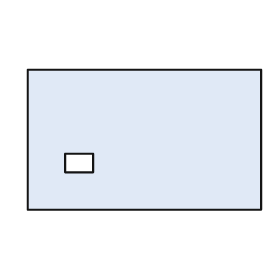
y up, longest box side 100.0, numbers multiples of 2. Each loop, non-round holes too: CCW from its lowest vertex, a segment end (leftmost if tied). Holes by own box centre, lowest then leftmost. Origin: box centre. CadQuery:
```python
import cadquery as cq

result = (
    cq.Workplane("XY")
    .moveTo(-50.0, -30.0)
    .lineTo(50.0, -30.0)
    .lineTo(50.0, 30.0)
    .lineTo(-50.0, 30.0)
    .close()
    .moveTo(-34.0, -14.0)
    .lineTo(-22.0, -14.0)
    .lineTo(-22.0, -6.0)
    .lineTo(-34.0, -6.0)
    .close()
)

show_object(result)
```